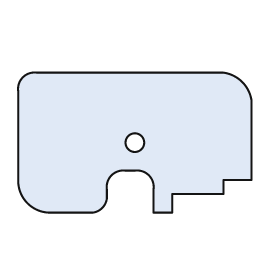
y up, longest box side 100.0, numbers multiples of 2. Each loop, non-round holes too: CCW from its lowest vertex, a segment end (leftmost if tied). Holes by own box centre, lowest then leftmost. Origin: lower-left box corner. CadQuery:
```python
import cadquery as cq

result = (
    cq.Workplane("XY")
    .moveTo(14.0, 0.0)
    .lineTo(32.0, 0.0)
    .threePointArc((36.0, 2.0), (38.0, 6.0))
    .lineTo(38.0, 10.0)
    .threePointArc((40.0, 16.0), (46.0, 18.0))
    .lineTo(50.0, 18.0)
    .threePointArc((56.0, 16.0), (58.0, 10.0))
    .lineTo(58.0, 0.0)
    .lineTo(66.0, 0.0)
    .lineTo(66.0, 8.0)
    .lineTo(88.0, 8.0)
    .lineTo(88.0, 14.0)
    .lineTo(100.0, 14.0)
    .lineTo(100.0, 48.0)
    .threePointArc((96.0, 56.0), (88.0, 60.0))
    .lineTo(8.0, 60.0)
    .threePointArc((2.0, 58.0), (0.0, 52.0))
    .lineTo(0.0, 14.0)
    .threePointArc((4.0, 4.0), (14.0, 0.0))
    .close()
    .moveTo(50.0, 30.0)
    .circle(4.0)
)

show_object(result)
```